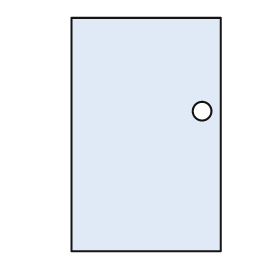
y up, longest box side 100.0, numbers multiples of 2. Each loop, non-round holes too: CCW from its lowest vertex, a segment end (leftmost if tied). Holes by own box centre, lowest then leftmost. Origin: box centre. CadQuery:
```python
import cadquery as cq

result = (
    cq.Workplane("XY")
    .moveTo(-32.0, -50.0)
    .lineTo(32.0, -50.0)
    .lineTo(32.0, 50.0)
    .lineTo(-32.0, 50.0)
    .close()
    .moveTo(24.0, 10.0)
    .circle(4.0)
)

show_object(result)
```